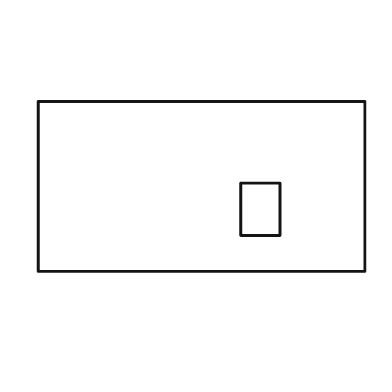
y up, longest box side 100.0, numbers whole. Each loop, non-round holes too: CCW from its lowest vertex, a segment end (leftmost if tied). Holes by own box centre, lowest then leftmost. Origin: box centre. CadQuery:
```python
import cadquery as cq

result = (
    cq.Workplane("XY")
    .moveTo(-50.0, -26.0)
    .lineTo(50.0, -26.0)
    .lineTo(50.0, 26.0)
    .lineTo(-50.0, 26.0)
    .close()
    .moveTo(12.0, -15.0)
    .lineTo(24.0, -15.0)
    .lineTo(24.0, 1.0)
    .lineTo(12.0, 1.0)
    .close()
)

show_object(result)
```